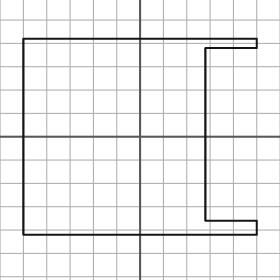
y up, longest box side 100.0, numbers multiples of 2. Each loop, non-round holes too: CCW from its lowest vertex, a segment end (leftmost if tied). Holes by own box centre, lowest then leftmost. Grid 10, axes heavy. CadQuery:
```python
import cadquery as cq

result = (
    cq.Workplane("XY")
    .moveTo(-50.0, -42.0)
    .lineTo(50.0, -42.0)
    .lineTo(50.0, -36.0)
    .lineTo(28.0, -36.0)
    .lineTo(28.0, 38.0)
    .lineTo(50.0, 38.0)
    .lineTo(50.0, 42.0)
    .lineTo(-50.0, 42.0)
    .close()
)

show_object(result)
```